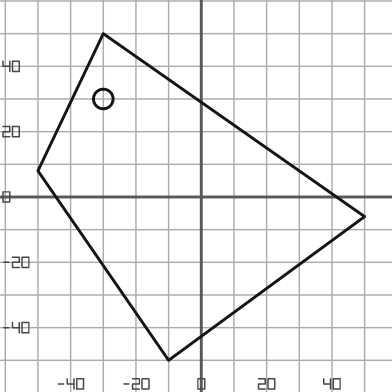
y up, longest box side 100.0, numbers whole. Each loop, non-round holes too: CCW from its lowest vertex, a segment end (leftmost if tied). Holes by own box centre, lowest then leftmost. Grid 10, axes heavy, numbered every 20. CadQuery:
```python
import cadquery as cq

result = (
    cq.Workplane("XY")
    .moveTo(-10.0, -50.0)
    .lineTo(50.0, -6.0)
    .lineTo(-30.0, 50.0)
    .lineTo(-50.0, 8.0)
    .close()
    .moveTo(-30.0, 30.0)
    .circle(3.0)
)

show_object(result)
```